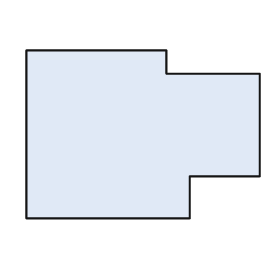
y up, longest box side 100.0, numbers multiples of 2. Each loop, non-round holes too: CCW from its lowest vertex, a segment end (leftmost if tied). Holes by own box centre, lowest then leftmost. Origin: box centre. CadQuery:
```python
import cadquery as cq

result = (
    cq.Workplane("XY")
    .moveTo(-50.0, -36.0)
    .lineTo(20.0, -36.0)
    .lineTo(20.0, -18.0)
    .lineTo(50.0, -18.0)
    .lineTo(50.0, 26.0)
    .lineTo(10.0, 26.0)
    .lineTo(10.0, 36.0)
    .lineTo(-50.0, 36.0)
    .close()
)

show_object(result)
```